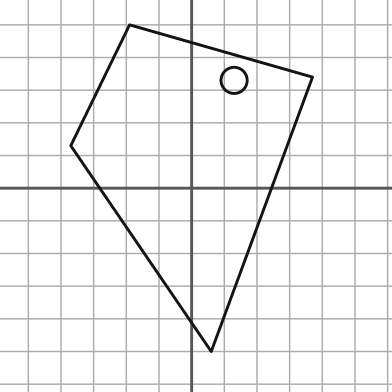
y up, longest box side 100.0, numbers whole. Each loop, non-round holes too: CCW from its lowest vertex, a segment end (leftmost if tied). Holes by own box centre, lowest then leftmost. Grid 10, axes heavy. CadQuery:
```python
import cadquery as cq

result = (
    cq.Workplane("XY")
    .moveTo(6.0, -50.0)
    .lineTo(37.0, 34.0)
    .lineTo(-19.0, 50.0)
    .lineTo(-37.0, 13.0)
    .close()
    .moveTo(13.0, 33.0)
    .circle(4.0)
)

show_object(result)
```